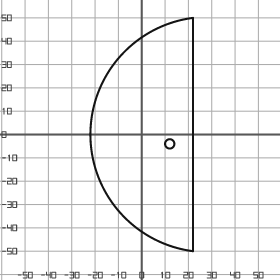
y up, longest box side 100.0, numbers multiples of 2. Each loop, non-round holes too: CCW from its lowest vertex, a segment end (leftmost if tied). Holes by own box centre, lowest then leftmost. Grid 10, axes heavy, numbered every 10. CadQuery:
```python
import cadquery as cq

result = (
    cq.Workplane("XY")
    .moveTo(22.0, -50.0)
    .lineTo(22.0, 50.0)
    .threePointArc((-22.0, 0.0), (22.0, -50.0))
    .close()
    .moveTo(12.0, -4.0)
    .circle(2.0)
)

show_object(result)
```